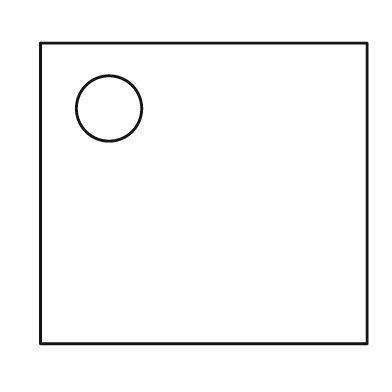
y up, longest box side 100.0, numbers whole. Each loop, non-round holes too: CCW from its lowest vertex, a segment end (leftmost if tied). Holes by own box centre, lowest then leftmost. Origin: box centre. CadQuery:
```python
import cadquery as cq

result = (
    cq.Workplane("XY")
    .moveTo(-50.0, -46.0)
    .lineTo(50.0, -46.0)
    .lineTo(50.0, 46.0)
    .lineTo(-50.0, 46.0)
    .close()
    .moveTo(-29.0, 26.0)
    .circle(10.0)
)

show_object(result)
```